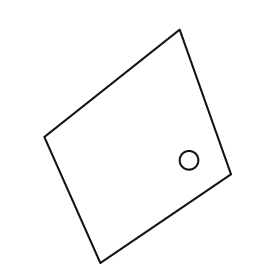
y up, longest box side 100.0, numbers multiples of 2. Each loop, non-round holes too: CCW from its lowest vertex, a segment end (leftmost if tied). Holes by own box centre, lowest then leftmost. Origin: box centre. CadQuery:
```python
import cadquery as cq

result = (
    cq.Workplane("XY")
    .moveTo(-16.0, -50.0)
    .lineTo(40.0, -12.0)
    .lineTo(18.0, 50.0)
    .lineTo(-40.0, 4.0)
    .close()
    .moveTo(22.0, -6.0)
    .circle(4.0)
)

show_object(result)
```